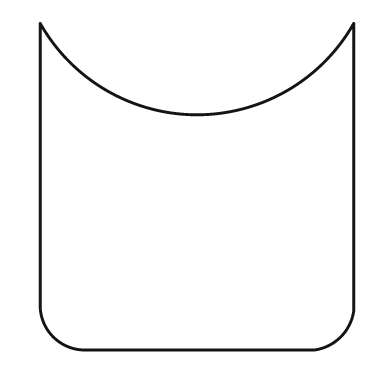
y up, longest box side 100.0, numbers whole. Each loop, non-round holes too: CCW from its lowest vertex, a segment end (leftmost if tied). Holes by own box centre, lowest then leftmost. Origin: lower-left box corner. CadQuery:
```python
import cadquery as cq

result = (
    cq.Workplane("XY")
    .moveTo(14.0, 0.0)
    .lineTo(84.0, 0.0)
    .threePointArc((92.0, 4.0), (96.0, 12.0))
    .lineTo(96.0, 100.0)
    .threePointArc((48.0, 72.0), (0.0, 100.0))
    .lineTo(0.0, 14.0)
    .threePointArc((4.0, 4.0), (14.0, 0.0))
    .close()
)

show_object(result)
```